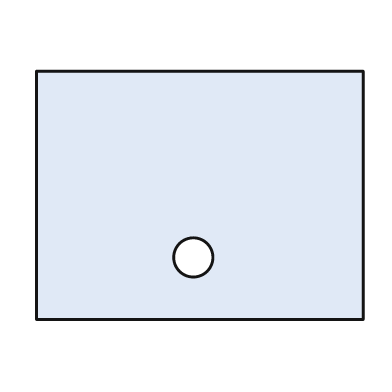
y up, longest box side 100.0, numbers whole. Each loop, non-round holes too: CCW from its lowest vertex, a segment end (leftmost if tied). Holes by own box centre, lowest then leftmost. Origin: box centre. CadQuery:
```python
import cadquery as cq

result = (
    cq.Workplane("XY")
    .moveTo(-50.0, -38.0)
    .lineTo(50.0, -38.0)
    .lineTo(50.0, 38.0)
    .lineTo(-50.0, 38.0)
    .close()
    .moveTo(-2.0, -19.0)
    .circle(6.0)
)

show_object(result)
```